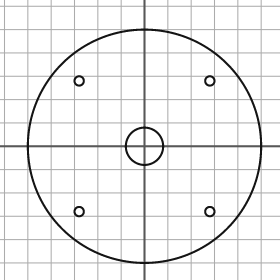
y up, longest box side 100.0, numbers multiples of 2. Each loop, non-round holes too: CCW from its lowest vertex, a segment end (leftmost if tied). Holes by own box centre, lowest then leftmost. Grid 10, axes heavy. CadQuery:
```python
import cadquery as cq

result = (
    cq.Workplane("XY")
    .moveTo(0.0, 0.0)
    .circle(50.0)
    .moveTo(-28.0, -28.0)
    .circle(2.0)
    .moveTo(28.0, -28.0)
    .circle(2.0)
    .moveTo(0.0, 0.0)
    .circle(8.0)
    .moveTo(-28.0, 28.0)
    .circle(2.0)
    .moveTo(28.0, 28.0)
    .circle(2.0)
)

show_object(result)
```